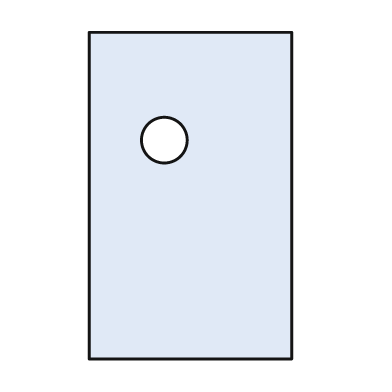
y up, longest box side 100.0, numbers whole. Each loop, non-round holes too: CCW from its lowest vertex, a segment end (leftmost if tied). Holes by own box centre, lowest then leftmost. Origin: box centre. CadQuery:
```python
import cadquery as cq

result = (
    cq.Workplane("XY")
    .moveTo(-31.0, -50.0)
    .lineTo(31.0, -50.0)
    .lineTo(31.0, 50.0)
    .lineTo(-31.0, 50.0)
    .close()
    .moveTo(-8.0, 17.0)
    .circle(7.0)
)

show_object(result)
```